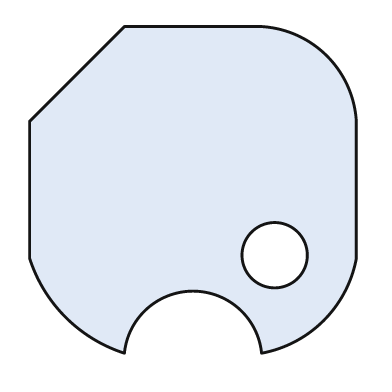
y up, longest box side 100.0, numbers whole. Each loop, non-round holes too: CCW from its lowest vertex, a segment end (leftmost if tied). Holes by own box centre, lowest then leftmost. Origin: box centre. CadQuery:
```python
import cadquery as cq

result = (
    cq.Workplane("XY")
    .moveTo(-21.0, -50.0)
    .threePointArc((0.0, -31.0), (21.0, -50.0))
    .threePointArc((40.0, -40.0), (50.0, -21.0))
    .lineTo(50.0, 21.0)
    .threePointArc((41.0, 41.0), (21.0, 50.0))
    .lineTo(-21.0, 50.0)
    .lineTo(-50.0, 21.0)
    .lineTo(-50.0, -21.0)
    .threePointArc((-39.0, -39.0), (-21.0, -50.0))
    .close()
    .moveTo(25.0, -20.0)
    .circle(10.0)
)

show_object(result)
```